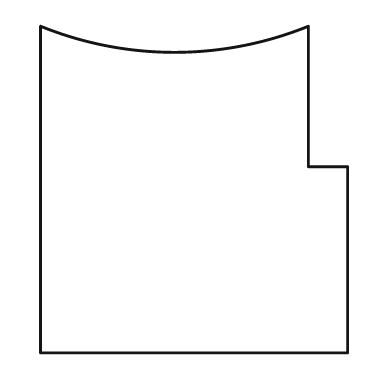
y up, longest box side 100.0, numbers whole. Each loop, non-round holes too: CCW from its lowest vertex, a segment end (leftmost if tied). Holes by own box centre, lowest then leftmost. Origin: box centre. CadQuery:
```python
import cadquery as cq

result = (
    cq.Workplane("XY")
    .moveTo(-47.0, -50.0)
    .lineTo(47.0, -50.0)
    .lineTo(47.0, 7.0)
    .lineTo(35.0, 7.0)
    .lineTo(35.0, 50.0)
    .threePointArc((-6.0, 42.0), (-47.0, 50.0))
    .close()
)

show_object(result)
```